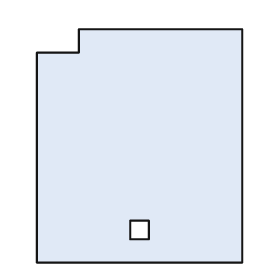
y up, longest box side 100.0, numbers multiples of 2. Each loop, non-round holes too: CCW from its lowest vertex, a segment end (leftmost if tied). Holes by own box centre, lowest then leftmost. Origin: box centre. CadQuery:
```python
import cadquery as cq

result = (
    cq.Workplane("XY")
    .moveTo(-44.0, -50.0)
    .lineTo(44.0, -50.0)
    .lineTo(44.0, 50.0)
    .lineTo(-26.0, 50.0)
    .lineTo(-26.0, 40.0)
    .lineTo(-44.0, 40.0)
    .close()
    .moveTo(-4.0, -40.0)
    .lineTo(4.0, -40.0)
    .lineTo(4.0, -32.0)
    .lineTo(-4.0, -32.0)
    .close()
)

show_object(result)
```